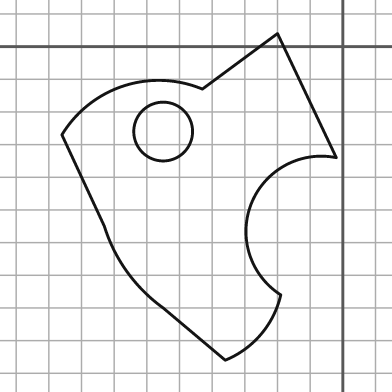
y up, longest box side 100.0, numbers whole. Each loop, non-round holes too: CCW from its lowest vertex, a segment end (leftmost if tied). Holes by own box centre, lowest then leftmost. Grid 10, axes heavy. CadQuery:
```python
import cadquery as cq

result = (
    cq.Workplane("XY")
    .moveTo(-36.0, -96.0)
    .threePointArc((-25.0, -88.0), (-19.0, -76.0))
    .threePointArc((-28.0, -48.0), (-2.0, -34.0))
    .lineTo(-20.0, 4.0)
    .lineTo(-43.0, -13.0)
    .threePointArc((-67.0, -12.0), (-86.0, -27.0))
    .lineTo(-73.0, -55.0)
    .threePointArc((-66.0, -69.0), (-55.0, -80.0))
    .close()
    .moveTo(-55.0, -26.0)
    .circle(9.0)
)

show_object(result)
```